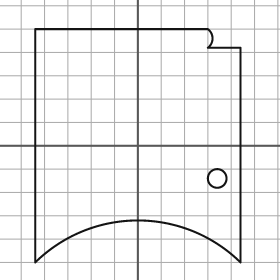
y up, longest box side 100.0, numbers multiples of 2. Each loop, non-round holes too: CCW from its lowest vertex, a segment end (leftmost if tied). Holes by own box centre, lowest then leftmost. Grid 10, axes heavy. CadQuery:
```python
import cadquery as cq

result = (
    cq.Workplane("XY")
    .moveTo(-44.0, -50.0)
    .threePointArc((0.0, -32.0), (44.0, -50.0))
    .lineTo(44.0, 42.0)
    .lineTo(30.0, 42.0)
    .threePointArc((32.0, 46.0), (30.0, 50.0))
    .lineTo(-44.0, 50.0)
    .close()
    .moveTo(34.0, -14.0)
    .circle(4.0)
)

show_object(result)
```